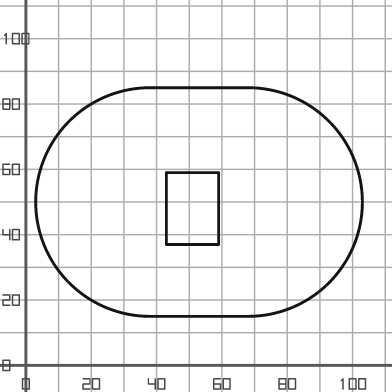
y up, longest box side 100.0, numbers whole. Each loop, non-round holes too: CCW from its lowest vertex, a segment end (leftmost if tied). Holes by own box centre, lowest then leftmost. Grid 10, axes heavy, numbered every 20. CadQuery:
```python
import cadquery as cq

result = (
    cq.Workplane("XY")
    .moveTo(38.0, 15.0)
    .lineTo(68.0, 15.0)
    .threePointArc((103.0, 50.0), (68.0, 85.0))
    .lineTo(38.0, 85.0)
    .threePointArc((3.0, 50.0), (38.0, 15.0))
    .close()
    .moveTo(43.0, 37.0)
    .lineTo(59.0, 37.0)
    .lineTo(59.0, 59.0)
    .lineTo(43.0, 59.0)
    .close()
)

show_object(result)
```